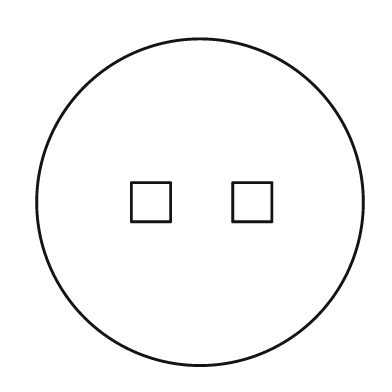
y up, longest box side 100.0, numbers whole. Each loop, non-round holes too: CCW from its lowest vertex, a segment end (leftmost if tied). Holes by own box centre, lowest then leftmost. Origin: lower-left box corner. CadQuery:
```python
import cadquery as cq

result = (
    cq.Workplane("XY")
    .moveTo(50.0, 50.0)
    .circle(50.0)
    .moveTo(29.0, 44.0)
    .lineTo(41.0, 44.0)
    .lineTo(41.0, 56.0)
    .lineTo(29.0, 56.0)
    .close()
    .moveTo(60.0, 44.0)
    .lineTo(72.0, 44.0)
    .lineTo(72.0, 56.0)
    .lineTo(60.0, 56.0)
    .close()
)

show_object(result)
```